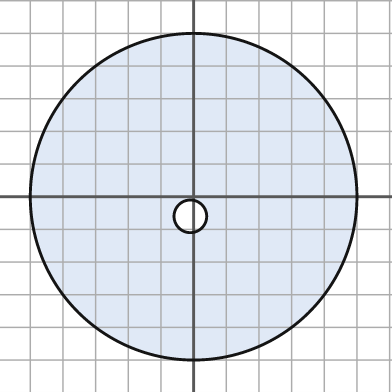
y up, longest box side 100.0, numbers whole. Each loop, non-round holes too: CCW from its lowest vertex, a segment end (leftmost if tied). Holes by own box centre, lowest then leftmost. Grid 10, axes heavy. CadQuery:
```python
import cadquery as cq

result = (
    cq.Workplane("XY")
    .moveTo(0.0, 0.0)
    .circle(50.0)
    .moveTo(-1.0, -6.0)
    .circle(5.0)
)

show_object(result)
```